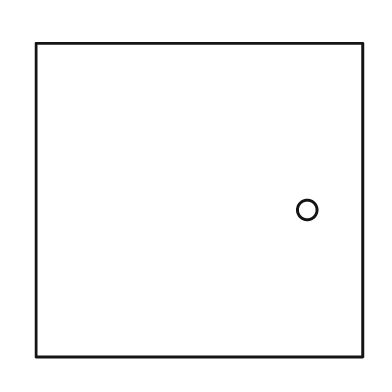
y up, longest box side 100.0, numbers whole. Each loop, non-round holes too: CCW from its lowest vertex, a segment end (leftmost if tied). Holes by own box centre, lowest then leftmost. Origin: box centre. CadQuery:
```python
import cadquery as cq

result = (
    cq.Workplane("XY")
    .moveTo(-50.0, -48.0)
    .lineTo(50.0, -48.0)
    .lineTo(50.0, 48.0)
    .lineTo(-50.0, 48.0)
    .close()
    .moveTo(33.0, -3.0)
    .circle(3.0)
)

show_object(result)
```